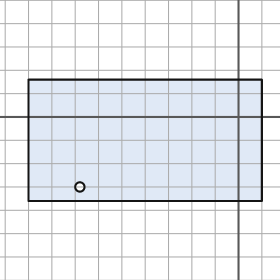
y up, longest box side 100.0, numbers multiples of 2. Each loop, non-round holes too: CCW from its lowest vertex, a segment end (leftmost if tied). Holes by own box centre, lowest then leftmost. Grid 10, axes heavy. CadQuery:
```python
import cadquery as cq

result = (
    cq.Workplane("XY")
    .moveTo(-90.0, -36.0)
    .lineTo(10.0, -36.0)
    .lineTo(10.0, 16.0)
    .lineTo(-90.0, 16.0)
    .close()
    .moveTo(-68.0, -30.0)
    .circle(2.0)
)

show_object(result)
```